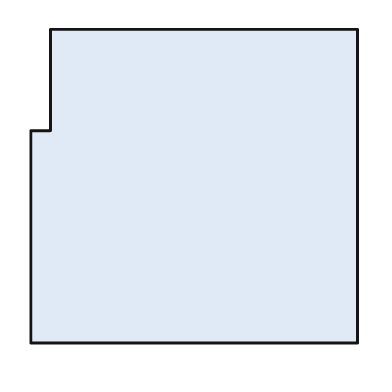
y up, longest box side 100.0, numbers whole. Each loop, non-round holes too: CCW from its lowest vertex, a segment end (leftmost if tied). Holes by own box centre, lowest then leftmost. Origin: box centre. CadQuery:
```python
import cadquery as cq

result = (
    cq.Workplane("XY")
    .moveTo(-50.0, -48.0)
    .lineTo(50.0, -48.0)
    .lineTo(50.0, 48.0)
    .lineTo(-44.0, 48.0)
    .lineTo(-44.0, 17.0)
    .lineTo(-50.0, 17.0)
    .close()
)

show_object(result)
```